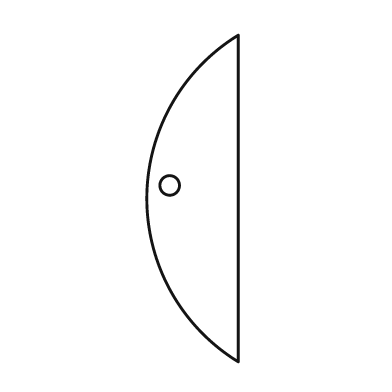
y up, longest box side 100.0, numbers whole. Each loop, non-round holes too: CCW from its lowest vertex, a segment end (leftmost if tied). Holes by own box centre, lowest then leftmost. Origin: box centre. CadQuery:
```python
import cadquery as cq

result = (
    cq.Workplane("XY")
    .moveTo(14.0, -50.0)
    .lineTo(14.0, 50.0)
    .threePointArc((-14.0, 0.0), (14.0, -50.0))
    .close()
    .moveTo(-7.0, 4.0)
    .circle(3.0)
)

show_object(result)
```